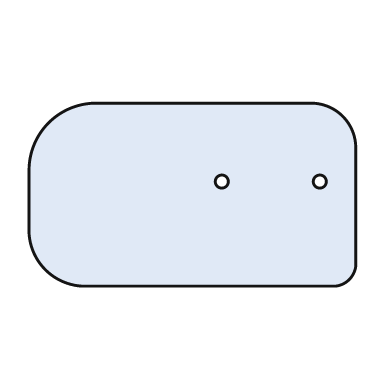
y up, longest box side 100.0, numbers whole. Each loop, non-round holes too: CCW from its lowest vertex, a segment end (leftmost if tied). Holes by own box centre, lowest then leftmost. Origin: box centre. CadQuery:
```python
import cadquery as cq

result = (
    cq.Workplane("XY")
    .moveTo(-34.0, -28.0)
    .lineTo(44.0, -28.0)
    .threePointArc((48.0, -26.0), (50.0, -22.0))
    .lineTo(50.0, 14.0)
    .threePointArc((46.0, 24.0), (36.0, 28.0))
    .lineTo(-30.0, 28.0)
    .threePointArc((-44.0, 22.0), (-50.0, 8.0))
    .lineTo(-50.0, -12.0)
    .threePointArc((-45.0, -23.0), (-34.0, -28.0))
    .close()
    .moveTo(9.0, 4.0)
    .circle(2.0)
    .moveTo(39.0, 4.0)
    .circle(2.0)
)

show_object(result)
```